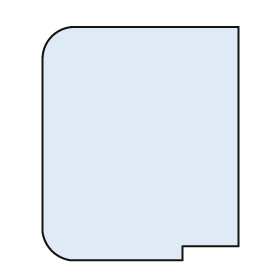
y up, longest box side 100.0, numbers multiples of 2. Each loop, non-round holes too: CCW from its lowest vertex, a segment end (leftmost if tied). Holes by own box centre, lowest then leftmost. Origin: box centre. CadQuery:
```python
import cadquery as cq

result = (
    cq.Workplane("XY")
    .moveTo(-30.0, -50.0)
    .lineTo(18.0, -50.0)
    .lineTo(18.0, -44.0)
    .lineTo(42.0, -44.0)
    .lineTo(42.0, 50.0)
    .lineTo(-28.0, 50.0)
    .threePointArc((-38.0, 46.0), (-42.0, 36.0))
    .lineTo(-42.0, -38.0)
    .threePointArc((-38.0, -46.0), (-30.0, -50.0))
    .close()
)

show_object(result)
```